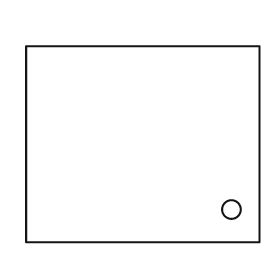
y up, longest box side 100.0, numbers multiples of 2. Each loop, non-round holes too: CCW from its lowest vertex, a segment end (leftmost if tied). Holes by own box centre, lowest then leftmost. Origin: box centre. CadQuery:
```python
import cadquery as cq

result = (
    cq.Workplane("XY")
    .moveTo(-50.0, -42.0)
    .lineTo(50.0, -42.0)
    .lineTo(50.0, 42.0)
    .lineTo(-50.0, 42.0)
    .close()
    .moveTo(38.0, -28.0)
    .circle(4.0)
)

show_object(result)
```